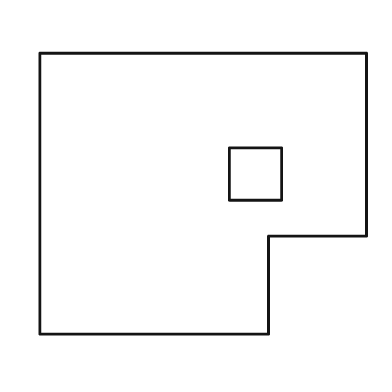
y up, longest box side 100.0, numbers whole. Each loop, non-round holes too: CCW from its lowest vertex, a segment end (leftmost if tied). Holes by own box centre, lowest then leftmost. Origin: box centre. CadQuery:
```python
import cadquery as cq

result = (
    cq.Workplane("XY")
    .moveTo(-50.0, -43.0)
    .lineTo(20.0, -43.0)
    .lineTo(20.0, -13.0)
    .lineTo(50.0, -13.0)
    .lineTo(50.0, 43.0)
    .lineTo(-50.0, 43.0)
    .close()
    .moveTo(8.0, -2.0)
    .lineTo(24.0, -2.0)
    .lineTo(24.0, 14.0)
    .lineTo(8.0, 14.0)
    .close()
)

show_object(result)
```